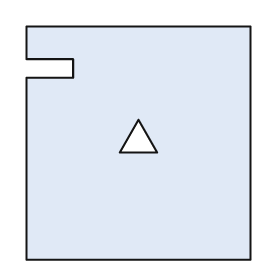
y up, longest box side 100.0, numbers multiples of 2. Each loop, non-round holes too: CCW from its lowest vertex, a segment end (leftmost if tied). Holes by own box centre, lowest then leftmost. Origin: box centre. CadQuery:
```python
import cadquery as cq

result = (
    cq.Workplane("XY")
    .moveTo(-48.0, -50.0)
    .lineTo(48.0, -50.0)
    .lineTo(48.0, 50.0)
    .lineTo(-48.0, 50.0)
    .lineTo(-48.0, 36.0)
    .lineTo(-28.0, 36.0)
    .lineTo(-28.0, 28.0)
    .lineTo(-48.0, 28.0)
    .close()
    .moveTo(-8.0, -4.0)
    .lineTo(8.0, -4.0)
    .lineTo(0.0, 10.0)
    .close()
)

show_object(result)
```